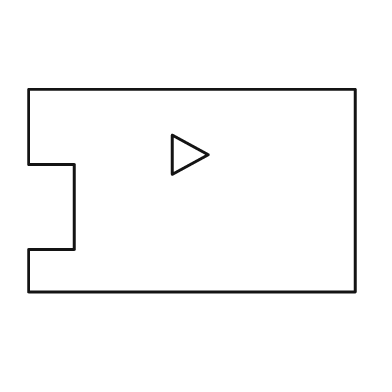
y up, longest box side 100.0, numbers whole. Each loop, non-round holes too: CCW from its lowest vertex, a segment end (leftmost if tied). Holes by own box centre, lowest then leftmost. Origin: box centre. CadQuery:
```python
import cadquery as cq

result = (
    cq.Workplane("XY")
    .moveTo(-50.0, -31.0)
    .lineTo(50.0, -31.0)
    .lineTo(50.0, 31.0)
    .lineTo(-50.0, 31.0)
    .lineTo(-50.0, 8.0)
    .lineTo(-36.0, 8.0)
    .lineTo(-36.0, -18.0)
    .lineTo(-50.0, -18.0)
    .close()
    .moveTo(-6.0, 5.0)
    .lineTo(5.0, 11.0)
    .lineTo(-6.0, 17.0)
    .close()
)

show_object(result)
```